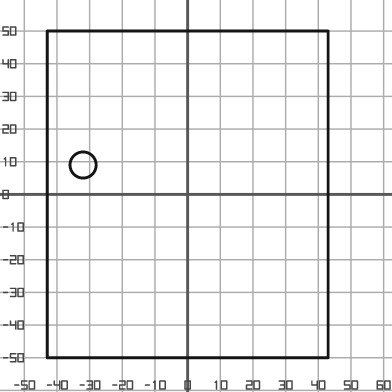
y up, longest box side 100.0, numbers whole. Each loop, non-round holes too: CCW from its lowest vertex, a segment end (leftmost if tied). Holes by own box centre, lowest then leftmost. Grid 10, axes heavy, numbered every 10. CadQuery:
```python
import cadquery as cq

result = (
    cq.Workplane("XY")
    .moveTo(-43.0, -50.0)
    .lineTo(43.0, -50.0)
    .lineTo(43.0, 50.0)
    .lineTo(-43.0, 50.0)
    .close()
    .moveTo(-32.0, 9.0)
    .circle(4.0)
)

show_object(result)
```